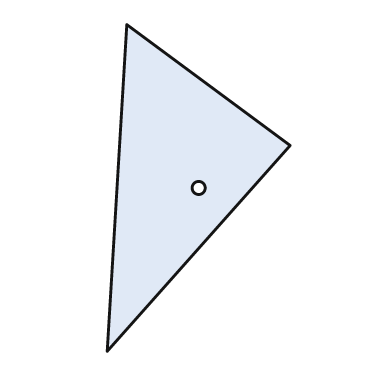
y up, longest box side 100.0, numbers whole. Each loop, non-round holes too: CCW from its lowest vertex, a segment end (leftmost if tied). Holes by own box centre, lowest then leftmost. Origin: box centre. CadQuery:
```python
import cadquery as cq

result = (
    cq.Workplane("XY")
    .moveTo(-28.0, -50.0)
    .lineTo(28.0, 13.0)
    .lineTo(-22.0, 50.0)
    .close()
    .moveTo(0.0, 0.0)
    .circle(2.0)
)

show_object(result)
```